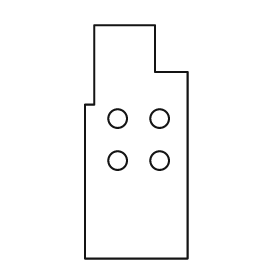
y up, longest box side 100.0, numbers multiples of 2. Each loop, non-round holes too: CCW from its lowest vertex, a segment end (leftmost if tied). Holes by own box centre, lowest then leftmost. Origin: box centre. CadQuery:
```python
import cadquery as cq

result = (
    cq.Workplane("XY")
    .moveTo(-22.0, -50.0)
    .lineTo(22.0, -50.0)
    .lineTo(22.0, 30.0)
    .lineTo(8.0, 30.0)
    .lineTo(8.0, 50.0)
    .lineTo(-18.0, 50.0)
    .lineTo(-18.0, 16.0)
    .lineTo(-22.0, 16.0)
    .close()
    .moveTo(-8.0, -8.0)
    .circle(4.0)
    .moveTo(10.0, -8.0)
    .circle(4.0)
    .moveTo(-8.0, 10.0)
    .circle(4.0)
    .moveTo(10.0, 10.0)
    .circle(4.0)
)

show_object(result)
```